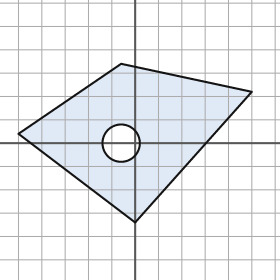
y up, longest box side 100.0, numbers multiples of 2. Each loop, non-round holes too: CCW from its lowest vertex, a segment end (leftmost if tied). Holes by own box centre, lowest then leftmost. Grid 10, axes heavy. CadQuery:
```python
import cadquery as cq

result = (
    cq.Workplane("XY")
    .moveTo(0.0, -34.0)
    .lineTo(50.0, 22.0)
    .lineTo(-6.0, 34.0)
    .lineTo(-50.0, 4.0)
    .close()
    .moveTo(-6.0, 0.0)
    .circle(8.0)
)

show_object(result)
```